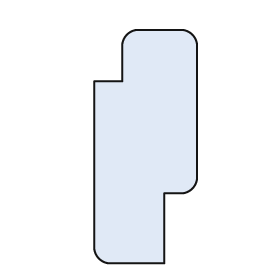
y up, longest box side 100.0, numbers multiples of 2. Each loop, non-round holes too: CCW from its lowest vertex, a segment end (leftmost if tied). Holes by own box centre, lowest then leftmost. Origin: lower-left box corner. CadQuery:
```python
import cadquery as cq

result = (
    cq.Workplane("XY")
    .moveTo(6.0, 0.0)
    .lineTo(30.0, 0.0)
    .lineTo(30.0, 30.0)
    .lineTo(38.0, 30.0)
    .threePointArc((42.0, 32.0), (44.0, 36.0))
    .lineTo(44.0, 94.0)
    .threePointArc((42.0, 98.0), (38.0, 100.0))
    .lineTo(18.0, 100.0)
    .threePointArc((14.0, 98.0), (12.0, 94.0))
    .lineTo(12.0, 78.0)
    .lineTo(0.0, 78.0)
    .lineTo(0.0, 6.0)
    .threePointArc((2.0, 2.0), (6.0, 0.0))
    .close()
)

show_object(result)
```